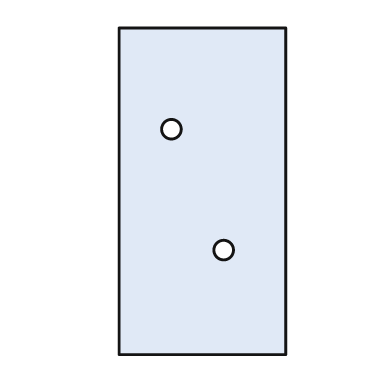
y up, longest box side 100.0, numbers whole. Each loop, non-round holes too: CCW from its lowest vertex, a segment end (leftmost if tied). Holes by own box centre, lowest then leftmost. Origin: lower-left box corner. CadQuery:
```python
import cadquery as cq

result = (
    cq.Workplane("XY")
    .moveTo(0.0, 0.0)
    .lineTo(51.0, 0.0)
    .lineTo(51.0, 100.0)
    .lineTo(0.0, 100.0)
    .close()
    .moveTo(32.0, 32.0)
    .circle(3.0)
    .moveTo(16.0, 69.0)
    .circle(3.0)
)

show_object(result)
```